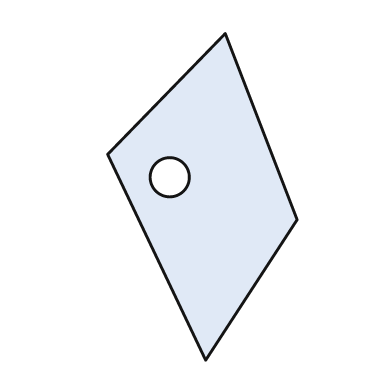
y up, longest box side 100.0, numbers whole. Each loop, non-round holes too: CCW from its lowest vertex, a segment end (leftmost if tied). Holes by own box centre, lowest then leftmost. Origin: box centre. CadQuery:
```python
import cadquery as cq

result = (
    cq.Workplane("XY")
    .moveTo(1.0, -50.0)
    .lineTo(29.0, -7.0)
    .lineTo(7.0, 50.0)
    .lineTo(-29.0, 13.0)
    .close()
    .moveTo(-10.0, 6.0)
    .circle(6.0)
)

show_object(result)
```